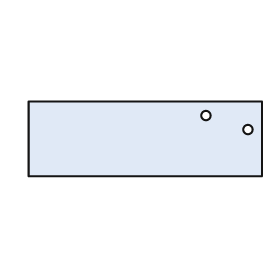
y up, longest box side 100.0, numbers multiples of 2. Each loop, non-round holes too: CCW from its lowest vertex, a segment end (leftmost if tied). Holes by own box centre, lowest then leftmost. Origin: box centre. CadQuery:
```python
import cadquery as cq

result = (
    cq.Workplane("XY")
    .moveTo(-50.0, -16.0)
    .lineTo(50.0, -16.0)
    .lineTo(50.0, 16.0)
    .lineTo(-50.0, 16.0)
    .close()
    .moveTo(44.0, 4.0)
    .circle(2.0)
    .moveTo(26.0, 10.0)
    .circle(2.0)
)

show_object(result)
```